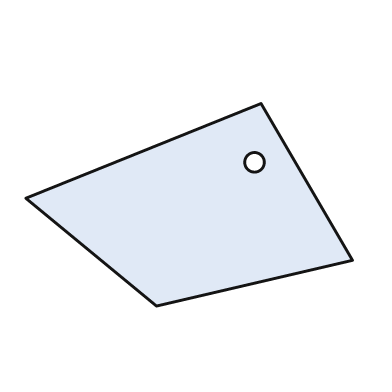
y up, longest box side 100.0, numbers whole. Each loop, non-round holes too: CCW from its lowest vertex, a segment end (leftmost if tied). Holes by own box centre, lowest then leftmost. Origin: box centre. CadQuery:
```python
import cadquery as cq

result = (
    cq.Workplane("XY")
    .moveTo(-10.0, -31.0)
    .lineTo(50.0, -17.0)
    .lineTo(22.0, 31.0)
    .lineTo(-50.0, 2.0)
    .close()
    .moveTo(20.0, 13.0)
    .circle(3.0)
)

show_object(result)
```